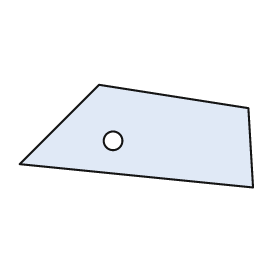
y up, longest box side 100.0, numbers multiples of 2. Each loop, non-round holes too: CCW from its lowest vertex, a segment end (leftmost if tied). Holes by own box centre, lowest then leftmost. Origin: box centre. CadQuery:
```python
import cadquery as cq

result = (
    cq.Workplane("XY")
    .moveTo(50.0, -22.0)
    .lineTo(48.0, 12.0)
    .lineTo(-16.0, 22.0)
    .lineTo(-50.0, -12.0)
    .close()
    .moveTo(-10.0, -2.0)
    .circle(4.0)
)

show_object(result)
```